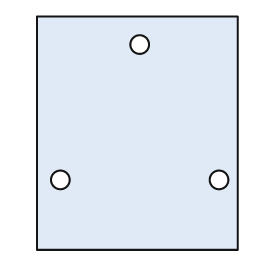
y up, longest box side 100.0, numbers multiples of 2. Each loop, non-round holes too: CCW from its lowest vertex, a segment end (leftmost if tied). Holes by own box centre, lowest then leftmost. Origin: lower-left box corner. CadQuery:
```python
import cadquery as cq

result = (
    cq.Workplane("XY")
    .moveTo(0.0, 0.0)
    .lineTo(86.0, 0.0)
    .lineTo(86.0, 100.0)
    .lineTo(0.0, 100.0)
    .close()
    .moveTo(10.0, 30.0)
    .circle(4.0)
    .moveTo(78.0, 30.0)
    .circle(4.0)
    .moveTo(44.0, 88.0)
    .circle(4.0)
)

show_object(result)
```